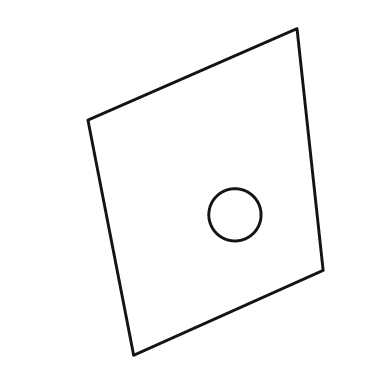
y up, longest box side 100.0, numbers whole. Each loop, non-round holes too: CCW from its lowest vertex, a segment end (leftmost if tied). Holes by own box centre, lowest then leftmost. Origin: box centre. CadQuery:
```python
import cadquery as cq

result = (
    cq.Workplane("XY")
    .moveTo(-22.0, -50.0)
    .lineTo(36.0, -24.0)
    .lineTo(28.0, 50.0)
    .lineTo(-36.0, 22.0)
    .close()
    .moveTo(9.0, -7.0)
    .circle(8.0)
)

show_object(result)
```